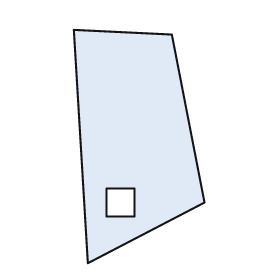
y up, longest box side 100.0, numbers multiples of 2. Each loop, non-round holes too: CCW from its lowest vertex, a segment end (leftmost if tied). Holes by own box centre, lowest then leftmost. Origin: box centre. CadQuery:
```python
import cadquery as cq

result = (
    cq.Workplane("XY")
    .moveTo(-22.0, -50.0)
    .lineTo(28.0, -24.0)
    .lineTo(14.0, 48.0)
    .lineTo(-28.0, 50.0)
    .close()
    .moveTo(-14.0, -30.0)
    .lineTo(-2.0, -30.0)
    .lineTo(-2.0, -18.0)
    .lineTo(-14.0, -18.0)
    .close()
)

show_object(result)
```